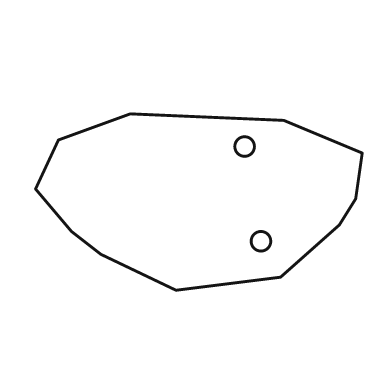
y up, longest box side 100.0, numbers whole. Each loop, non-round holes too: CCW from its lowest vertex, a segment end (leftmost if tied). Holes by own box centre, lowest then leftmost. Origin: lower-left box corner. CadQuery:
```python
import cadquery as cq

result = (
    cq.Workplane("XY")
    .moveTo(43.0, 0.0)
    .lineTo(75.0, 4.0)
    .lineTo(93.0, 20.0)
    .lineTo(98.0, 28.0)
    .lineTo(100.0, 42.0)
    .lineTo(76.0, 52.0)
    .lineTo(29.0, 54.0)
    .lineTo(7.0, 46.0)
    .lineTo(0.0, 31.0)
    .lineTo(11.0, 18.0)
    .lineTo(20.0, 11.0)
    .close()
    .moveTo(69.0, 15.0)
    .circle(3.0)
    .moveTo(64.0, 44.0)
    .circle(3.0)
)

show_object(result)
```